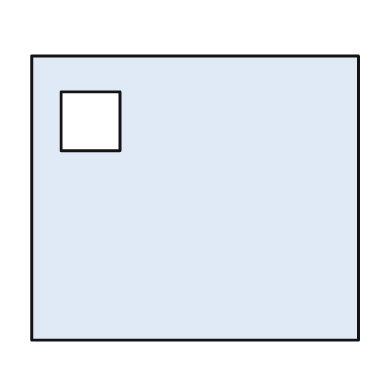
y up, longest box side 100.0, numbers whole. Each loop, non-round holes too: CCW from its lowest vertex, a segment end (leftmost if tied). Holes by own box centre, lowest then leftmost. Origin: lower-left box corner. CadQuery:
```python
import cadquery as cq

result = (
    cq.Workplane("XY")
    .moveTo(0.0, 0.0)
    .lineTo(100.0, 0.0)
    .lineTo(100.0, 87.0)
    .lineTo(0.0, 87.0)
    .close()
    .moveTo(9.0, 58.0)
    .lineTo(27.0, 58.0)
    .lineTo(27.0, 76.0)
    .lineTo(9.0, 76.0)
    .close()
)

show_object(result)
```